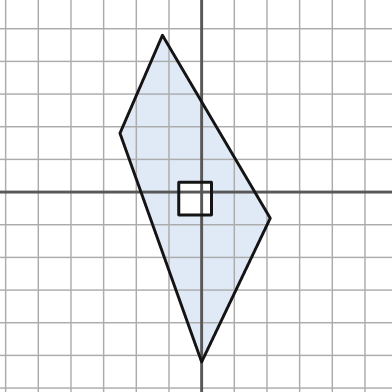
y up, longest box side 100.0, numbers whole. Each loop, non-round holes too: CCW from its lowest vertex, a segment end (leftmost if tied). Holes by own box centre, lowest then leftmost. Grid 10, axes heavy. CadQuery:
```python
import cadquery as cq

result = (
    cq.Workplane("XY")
    .moveTo(0.0, -52.0)
    .lineTo(21.0, -8.0)
    .lineTo(-12.0, 48.0)
    .lineTo(-25.0, 18.0)
    .close()
    .moveTo(-7.0, -7.0)
    .lineTo(3.0, -7.0)
    .lineTo(3.0, 3.0)
    .lineTo(-7.0, 3.0)
    .close()
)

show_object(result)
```